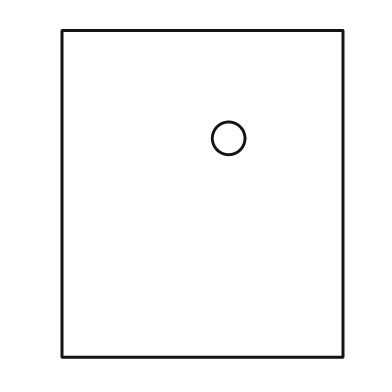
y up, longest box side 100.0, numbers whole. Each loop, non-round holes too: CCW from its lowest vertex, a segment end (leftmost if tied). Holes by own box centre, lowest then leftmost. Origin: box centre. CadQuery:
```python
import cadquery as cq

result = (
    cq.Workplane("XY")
    .moveTo(-43.0, -50.0)
    .lineTo(43.0, -50.0)
    .lineTo(43.0, 50.0)
    .lineTo(-43.0, 50.0)
    .close()
    .moveTo(8.0, 17.0)
    .circle(5.0)
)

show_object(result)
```